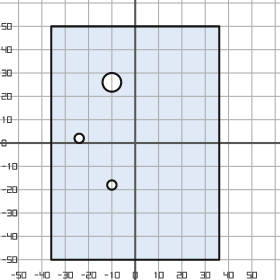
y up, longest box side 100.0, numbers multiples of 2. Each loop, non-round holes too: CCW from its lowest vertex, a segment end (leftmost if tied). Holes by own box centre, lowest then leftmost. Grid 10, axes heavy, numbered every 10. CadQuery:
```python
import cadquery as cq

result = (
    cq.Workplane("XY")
    .moveTo(-36.0, -50.0)
    .lineTo(36.0, -50.0)
    .lineTo(36.0, 50.0)
    .lineTo(-36.0, 50.0)
    .close()
    .moveTo(-10.0, -18.0)
    .circle(2.0)
    .moveTo(-24.0, 2.0)
    .circle(2.0)
    .moveTo(-10.0, 26.0)
    .circle(4.0)
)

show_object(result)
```